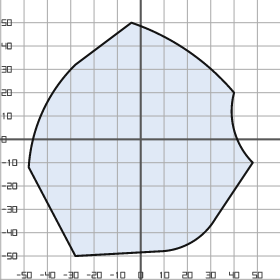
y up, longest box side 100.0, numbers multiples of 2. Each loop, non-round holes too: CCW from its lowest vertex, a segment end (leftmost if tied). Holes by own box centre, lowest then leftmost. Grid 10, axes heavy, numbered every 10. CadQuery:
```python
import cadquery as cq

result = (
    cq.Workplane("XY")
    .moveTo(-28.0, -50.0)
    .lineTo(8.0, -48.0)
    .threePointArc((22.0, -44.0), (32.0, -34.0))
    .lineTo(48.0, -10.0)
    .threePointArc((40.0, 4.0), (40.0, 20.0))
    .threePointArc((20.0, 38.0), (-4.0, 50.0))
    .lineTo(-28.0, 32.0)
    .threePointArc((-42.0, 12.0), (-48.0, -12.0))
    .close()
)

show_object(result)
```